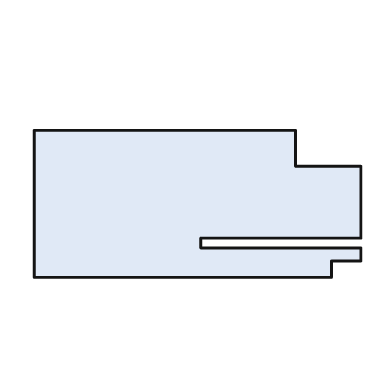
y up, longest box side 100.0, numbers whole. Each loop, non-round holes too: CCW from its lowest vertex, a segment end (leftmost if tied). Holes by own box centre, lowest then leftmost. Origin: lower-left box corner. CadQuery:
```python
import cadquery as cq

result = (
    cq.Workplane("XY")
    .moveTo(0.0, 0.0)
    .lineTo(91.0, 0.0)
    .lineTo(91.0, 5.0)
    .lineTo(100.0, 5.0)
    .lineTo(100.0, 9.0)
    .lineTo(51.0, 9.0)
    .lineTo(51.0, 12.0)
    .lineTo(100.0, 12.0)
    .lineTo(100.0, 34.0)
    .lineTo(80.0, 34.0)
    .lineTo(80.0, 45.0)
    .lineTo(0.0, 45.0)
    .close()
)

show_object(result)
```